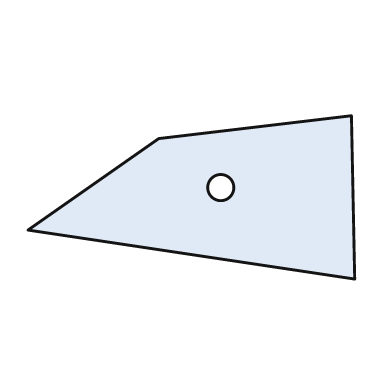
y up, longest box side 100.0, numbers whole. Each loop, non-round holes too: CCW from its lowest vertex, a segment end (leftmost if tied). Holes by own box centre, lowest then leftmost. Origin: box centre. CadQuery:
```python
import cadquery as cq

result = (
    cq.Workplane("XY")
    .moveTo(50.0, -25.0)
    .lineTo(49.0, 25.0)
    .lineTo(-10.0, 18.0)
    .lineTo(-50.0, -10.0)
    .close()
    .moveTo(9.0, 3.0)
    .circle(4.0)
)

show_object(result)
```